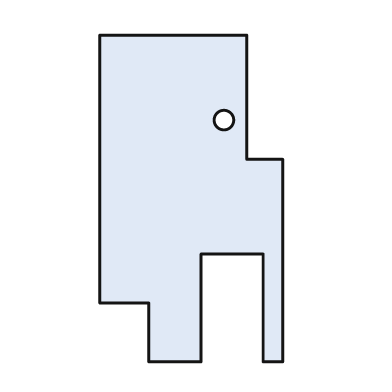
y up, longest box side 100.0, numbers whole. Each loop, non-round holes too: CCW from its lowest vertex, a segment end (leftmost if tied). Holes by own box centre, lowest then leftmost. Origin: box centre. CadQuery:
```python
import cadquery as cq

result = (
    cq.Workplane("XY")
    .moveTo(-13.0, -50.0)
    .lineTo(3.0, -50.0)
    .lineTo(3.0, -17.0)
    .lineTo(22.0, -17.0)
    .lineTo(22.0, -50.0)
    .lineTo(28.0, -50.0)
    .lineTo(28.0, 12.0)
    .lineTo(17.0, 12.0)
    .lineTo(17.0, 50.0)
    .lineTo(-28.0, 50.0)
    .lineTo(-28.0, -32.0)
    .lineTo(-13.0, -32.0)
    .close()
    .moveTo(10.0, 24.0)
    .circle(3.0)
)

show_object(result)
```